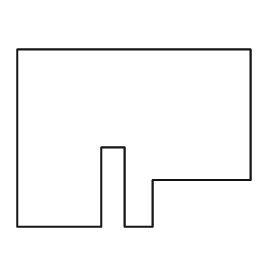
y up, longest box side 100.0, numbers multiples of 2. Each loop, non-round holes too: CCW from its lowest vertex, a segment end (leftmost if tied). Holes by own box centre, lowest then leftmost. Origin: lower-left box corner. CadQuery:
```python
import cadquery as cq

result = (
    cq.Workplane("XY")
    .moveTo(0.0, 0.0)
    .lineTo(36.0, 0.0)
    .lineTo(36.0, 34.0)
    .lineTo(46.0, 34.0)
    .lineTo(46.0, 0.0)
    .lineTo(58.0, 0.0)
    .lineTo(58.0, 20.0)
    .lineTo(100.0, 20.0)
    .lineTo(100.0, 76.0)
    .lineTo(0.0, 76.0)
    .close()
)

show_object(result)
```